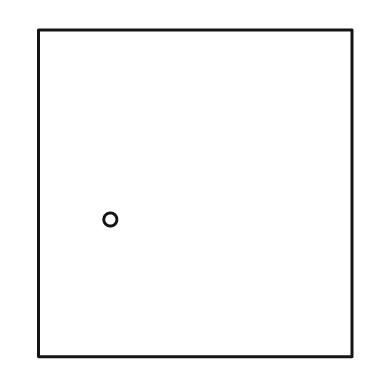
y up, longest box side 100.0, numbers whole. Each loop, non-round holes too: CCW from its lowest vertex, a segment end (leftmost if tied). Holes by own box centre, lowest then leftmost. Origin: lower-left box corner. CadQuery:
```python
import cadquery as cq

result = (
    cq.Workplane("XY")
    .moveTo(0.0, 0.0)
    .lineTo(96.0, 0.0)
    .lineTo(96.0, 100.0)
    .lineTo(0.0, 100.0)
    .close()
    .moveTo(22.0, 42.0)
    .circle(2.0)
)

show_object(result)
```